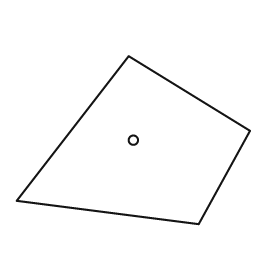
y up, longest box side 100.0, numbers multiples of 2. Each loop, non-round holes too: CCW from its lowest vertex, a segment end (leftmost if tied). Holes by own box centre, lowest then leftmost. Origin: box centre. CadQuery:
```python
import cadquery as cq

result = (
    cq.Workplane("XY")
    .moveTo(28.0, -36.0)
    .lineTo(50.0, 4.0)
    .lineTo(-2.0, 36.0)
    .lineTo(-50.0, -26.0)
    .close()
    .moveTo(0.0, 0.0)
    .circle(2.0)
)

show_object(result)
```